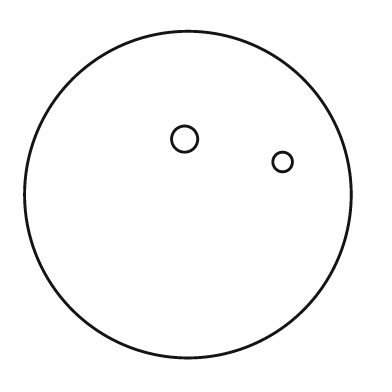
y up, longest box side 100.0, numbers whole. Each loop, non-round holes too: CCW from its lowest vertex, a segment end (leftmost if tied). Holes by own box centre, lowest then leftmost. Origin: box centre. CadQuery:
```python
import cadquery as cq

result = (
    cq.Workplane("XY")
    .moveTo(0.0, 0.0)
    .circle(50.0)
    .moveTo(29.0, 10.0)
    .circle(3.0)
    .moveTo(-1.0, 17.0)
    .circle(4.0)
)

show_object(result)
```